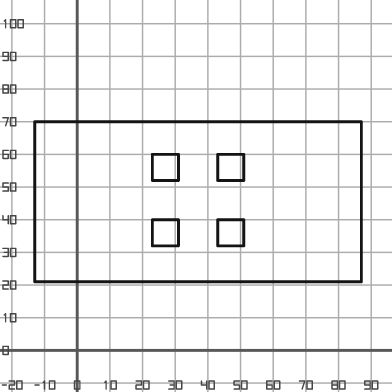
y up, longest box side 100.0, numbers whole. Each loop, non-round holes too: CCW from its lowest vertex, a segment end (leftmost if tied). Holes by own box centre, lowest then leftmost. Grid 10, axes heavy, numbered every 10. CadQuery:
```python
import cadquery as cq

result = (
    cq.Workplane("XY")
    .moveTo(-13.0, 21.0)
    .lineTo(87.0, 21.0)
    .lineTo(87.0, 70.0)
    .lineTo(-13.0, 70.0)
    .close()
    .moveTo(23.0, 32.0)
    .lineTo(31.0, 32.0)
    .lineTo(31.0, 40.0)
    .lineTo(23.0, 40.0)
    .close()
    .moveTo(43.0, 32.0)
    .lineTo(51.0, 32.0)
    .lineTo(51.0, 40.0)
    .lineTo(43.0, 40.0)
    .close()
    .moveTo(23.0, 52.0)
    .lineTo(31.0, 52.0)
    .lineTo(31.0, 60.0)
    .lineTo(23.0, 60.0)
    .close()
    .moveTo(43.0, 52.0)
    .lineTo(51.0, 52.0)
    .lineTo(51.0, 60.0)
    .lineTo(43.0, 60.0)
    .close()
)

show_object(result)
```